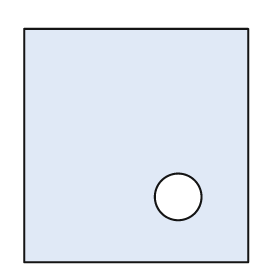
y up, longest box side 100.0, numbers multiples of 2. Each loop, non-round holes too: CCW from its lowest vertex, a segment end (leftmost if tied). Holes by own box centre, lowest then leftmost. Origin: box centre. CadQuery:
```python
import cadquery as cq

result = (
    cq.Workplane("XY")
    .moveTo(-48.0, -50.0)
    .lineTo(48.0, -50.0)
    .lineTo(48.0, 50.0)
    .lineTo(-48.0, 50.0)
    .close()
    .moveTo(18.0, -22.0)
    .circle(10.0)
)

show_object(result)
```